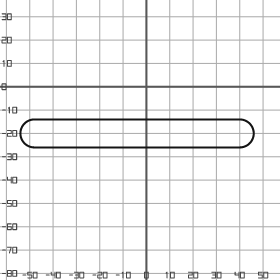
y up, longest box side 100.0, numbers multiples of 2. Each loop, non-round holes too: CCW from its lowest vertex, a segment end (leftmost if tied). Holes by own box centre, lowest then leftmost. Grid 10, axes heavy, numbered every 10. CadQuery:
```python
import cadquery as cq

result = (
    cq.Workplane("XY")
    .moveTo(-48.0, -26.0)
    .lineTo(40.0, -26.0)
    .threePointArc((46.0, -20.0), (40.0, -14.0))
    .lineTo(-48.0, -14.0)
    .threePointArc((-54.0, -20.0), (-48.0, -26.0))
    .close()
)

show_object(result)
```